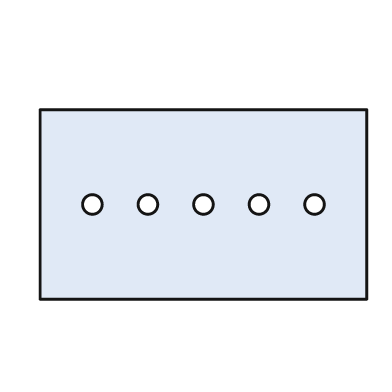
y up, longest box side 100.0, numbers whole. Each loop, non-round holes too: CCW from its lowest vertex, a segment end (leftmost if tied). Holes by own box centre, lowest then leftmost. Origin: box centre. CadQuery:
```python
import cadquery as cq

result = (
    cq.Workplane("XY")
    .moveTo(-50.0, -29.0)
    .lineTo(50.0, -29.0)
    .lineTo(50.0, 29.0)
    .lineTo(-50.0, 29.0)
    .close()
    .moveTo(-34.0, 0.0)
    .circle(3.0)
    .moveTo(-17.0, 0.0)
    .circle(3.0)
    .moveTo(0.0, 0.0)
    .circle(3.0)
    .moveTo(17.0, 0.0)
    .circle(3.0)
    .moveTo(34.0, 0.0)
    .circle(3.0)
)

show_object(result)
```